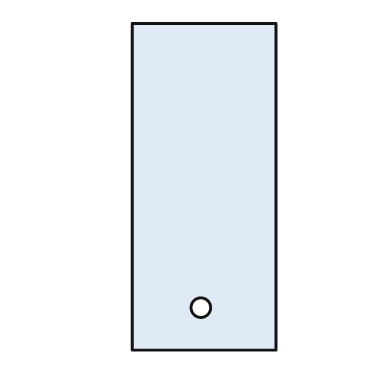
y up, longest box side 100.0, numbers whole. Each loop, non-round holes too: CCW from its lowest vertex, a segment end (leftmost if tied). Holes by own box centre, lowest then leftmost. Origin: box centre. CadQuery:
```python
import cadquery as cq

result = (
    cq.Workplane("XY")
    .moveTo(-22.0, -50.0)
    .lineTo(22.0, -50.0)
    .lineTo(22.0, 50.0)
    .lineTo(-22.0, 50.0)
    .close()
    .moveTo(-1.0, -37.0)
    .circle(3.0)
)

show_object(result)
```